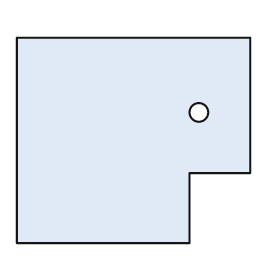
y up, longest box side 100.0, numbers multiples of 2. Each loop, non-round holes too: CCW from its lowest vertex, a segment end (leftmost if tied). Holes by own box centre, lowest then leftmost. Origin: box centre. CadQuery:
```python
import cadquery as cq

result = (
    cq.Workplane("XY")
    .moveTo(-50.0, -44.0)
    .lineTo(24.0, -44.0)
    .lineTo(24.0, -14.0)
    .lineTo(50.0, -14.0)
    .lineTo(50.0, 44.0)
    .lineTo(-50.0, 44.0)
    .close()
    .moveTo(28.0, 12.0)
    .circle(4.0)
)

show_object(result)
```